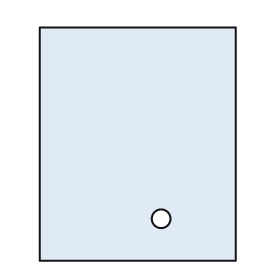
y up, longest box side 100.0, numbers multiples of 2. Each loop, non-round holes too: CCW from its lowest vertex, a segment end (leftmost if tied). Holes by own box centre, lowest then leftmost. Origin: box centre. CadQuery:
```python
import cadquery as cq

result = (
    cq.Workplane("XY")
    .moveTo(-42.0, -50.0)
    .lineTo(42.0, -50.0)
    .lineTo(42.0, 50.0)
    .lineTo(-42.0, 50.0)
    .close()
    .moveTo(10.0, -32.0)
    .circle(4.0)
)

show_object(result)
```